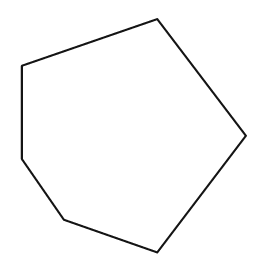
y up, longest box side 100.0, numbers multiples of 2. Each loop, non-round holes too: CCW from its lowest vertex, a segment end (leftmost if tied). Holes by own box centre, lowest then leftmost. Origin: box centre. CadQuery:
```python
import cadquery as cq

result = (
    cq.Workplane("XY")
    .moveTo(10.0, -50.0)
    .lineTo(48.0, 0.0)
    .lineTo(10.0, 50.0)
    .lineTo(-48.0, 30.0)
    .lineTo(-48.0, -10.0)
    .lineTo(-30.0, -36.0)
    .close()
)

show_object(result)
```